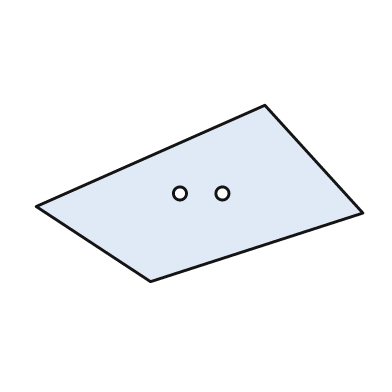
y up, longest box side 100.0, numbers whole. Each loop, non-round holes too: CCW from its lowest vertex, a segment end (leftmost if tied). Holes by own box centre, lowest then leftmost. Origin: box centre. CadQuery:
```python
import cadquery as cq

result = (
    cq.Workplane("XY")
    .moveTo(-15.0, -27.0)
    .lineTo(50.0, -6.0)
    .lineTo(20.0, 27.0)
    .lineTo(-50.0, -4.0)
    .close()
    .moveTo(-6.0, 0.0)
    .circle(2.0)
    .moveTo(7.0, 0.0)
    .circle(2.0)
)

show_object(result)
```